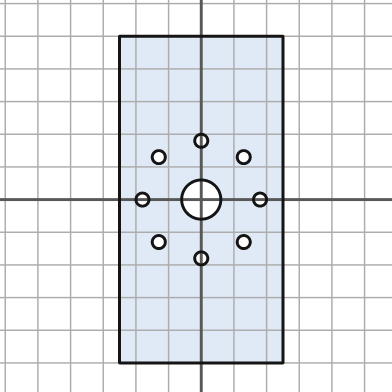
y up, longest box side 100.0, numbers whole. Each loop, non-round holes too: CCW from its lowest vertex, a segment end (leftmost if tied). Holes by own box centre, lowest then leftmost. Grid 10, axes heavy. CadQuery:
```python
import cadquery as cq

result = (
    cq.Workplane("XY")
    .moveTo(-25.0, -50.0)
    .lineTo(25.0, -50.0)
    .lineTo(25.0, 50.0)
    .lineTo(-25.0, 50.0)
    .close()
    .moveTo(0.0, -18.0)
    .circle(2.0)
    .moveTo(-13.0, -13.0)
    .circle(2.0)
    .moveTo(13.0, -13.0)
    .circle(2.0)
    .moveTo(-18.0, 0.0)
    .circle(2.0)
    .moveTo(0.0, 0.0)
    .circle(6.0)
    .moveTo(18.0, 0.0)
    .circle(2.0)
    .moveTo(-13.0, 13.0)
    .circle(2.0)
    .moveTo(13.0, 13.0)
    .circle(2.0)
    .moveTo(0.0, 18.0)
    .circle(2.0)
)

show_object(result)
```